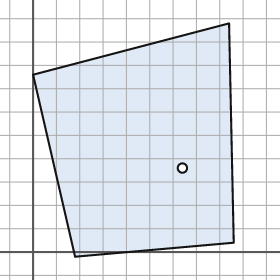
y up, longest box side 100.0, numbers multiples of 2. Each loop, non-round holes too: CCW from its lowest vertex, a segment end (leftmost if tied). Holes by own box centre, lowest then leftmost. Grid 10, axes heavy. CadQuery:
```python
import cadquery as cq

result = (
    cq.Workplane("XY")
    .moveTo(18.0, -2.0)
    .lineTo(86.0, 4.0)
    .lineTo(84.0, 98.0)
    .lineTo(0.0, 76.0)
    .close()
    .moveTo(64.0, 36.0)
    .circle(2.0)
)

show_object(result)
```